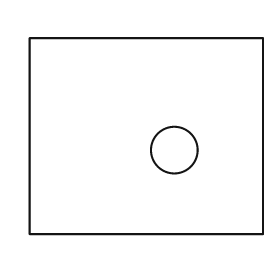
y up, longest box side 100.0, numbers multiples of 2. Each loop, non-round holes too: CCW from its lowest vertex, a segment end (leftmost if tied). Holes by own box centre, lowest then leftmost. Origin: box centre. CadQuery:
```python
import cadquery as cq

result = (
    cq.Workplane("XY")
    .moveTo(-50.0, -42.0)
    .lineTo(50.0, -42.0)
    .lineTo(50.0, 42.0)
    .lineTo(-50.0, 42.0)
    .close()
    .moveTo(12.0, -6.0)
    .circle(10.0)
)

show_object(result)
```